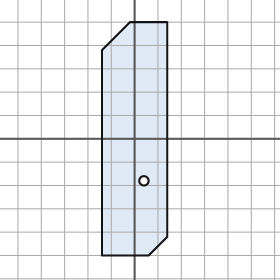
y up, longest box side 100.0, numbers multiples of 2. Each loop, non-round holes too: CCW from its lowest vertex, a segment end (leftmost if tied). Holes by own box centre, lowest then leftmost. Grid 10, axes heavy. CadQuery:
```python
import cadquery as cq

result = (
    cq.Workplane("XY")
    .moveTo(-14.0, -50.0)
    .lineTo(6.0, -50.0)
    .lineTo(14.0, -42.0)
    .lineTo(14.0, 50.0)
    .lineTo(-2.0, 50.0)
    .lineTo(-14.0, 38.0)
    .close()
    .moveTo(4.0, -18.0)
    .circle(2.0)
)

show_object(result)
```